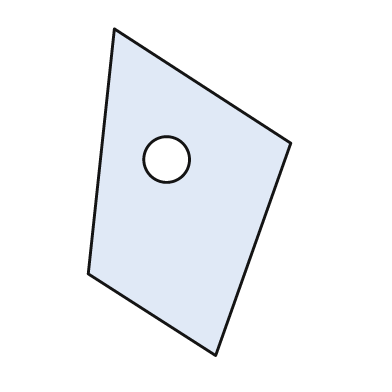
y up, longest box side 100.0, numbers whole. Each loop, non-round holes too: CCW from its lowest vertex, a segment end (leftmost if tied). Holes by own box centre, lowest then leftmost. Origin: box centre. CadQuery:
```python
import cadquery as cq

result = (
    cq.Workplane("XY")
    .moveTo(8.0, -50.0)
    .lineTo(31.0, 15.0)
    .lineTo(-23.0, 50.0)
    .lineTo(-31.0, -25.0)
    .close()
    .moveTo(-7.0, 10.0)
    .circle(7.0)
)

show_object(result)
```